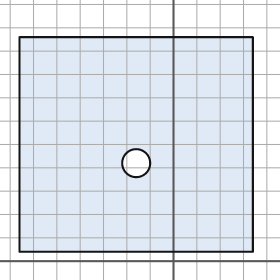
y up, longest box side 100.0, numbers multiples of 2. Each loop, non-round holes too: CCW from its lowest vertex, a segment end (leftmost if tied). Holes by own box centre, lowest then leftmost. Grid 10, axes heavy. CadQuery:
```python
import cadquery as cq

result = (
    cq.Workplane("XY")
    .moveTo(-66.0, 4.0)
    .lineTo(34.0, 4.0)
    .lineTo(34.0, 96.0)
    .lineTo(-66.0, 96.0)
    .close()
    .moveTo(-16.0, 42.0)
    .circle(6.0)
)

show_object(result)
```